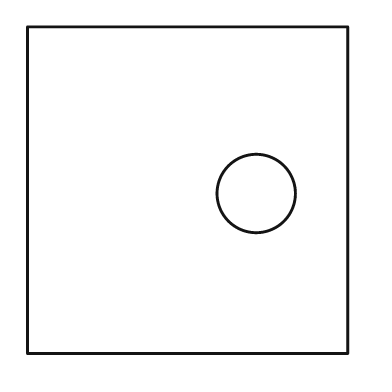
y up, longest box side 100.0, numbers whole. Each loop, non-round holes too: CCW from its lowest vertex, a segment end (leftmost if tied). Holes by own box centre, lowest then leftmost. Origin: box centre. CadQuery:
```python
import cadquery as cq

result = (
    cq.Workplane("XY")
    .moveTo(-49.0, -50.0)
    .lineTo(49.0, -50.0)
    .lineTo(49.0, 50.0)
    .lineTo(-49.0, 50.0)
    .close()
    .moveTo(21.0, -1.0)
    .circle(12.0)
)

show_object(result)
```